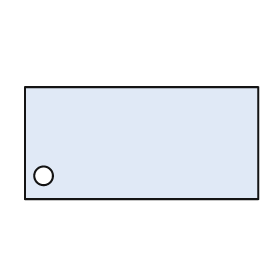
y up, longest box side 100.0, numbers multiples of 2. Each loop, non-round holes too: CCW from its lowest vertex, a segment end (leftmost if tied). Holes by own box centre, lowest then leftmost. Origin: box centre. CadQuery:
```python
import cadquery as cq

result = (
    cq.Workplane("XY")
    .moveTo(-50.0, -24.0)
    .lineTo(50.0, -24.0)
    .lineTo(50.0, 24.0)
    .lineTo(-50.0, 24.0)
    .close()
    .moveTo(-42.0, -14.0)
    .circle(4.0)
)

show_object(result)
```